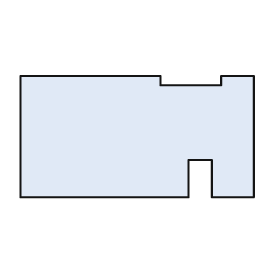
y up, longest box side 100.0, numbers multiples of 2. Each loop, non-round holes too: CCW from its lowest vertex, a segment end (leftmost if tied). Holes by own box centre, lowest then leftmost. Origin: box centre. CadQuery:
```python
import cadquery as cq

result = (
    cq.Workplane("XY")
    .moveTo(-50.0, -26.0)
    .lineTo(22.0, -26.0)
    .lineTo(22.0, -10.0)
    .lineTo(32.0, -10.0)
    .lineTo(32.0, -26.0)
    .lineTo(50.0, -26.0)
    .lineTo(50.0, 26.0)
    .lineTo(36.0, 26.0)
    .lineTo(36.0, 22.0)
    .lineTo(10.0, 22.0)
    .lineTo(10.0, 26.0)
    .lineTo(-50.0, 26.0)
    .close()
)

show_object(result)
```